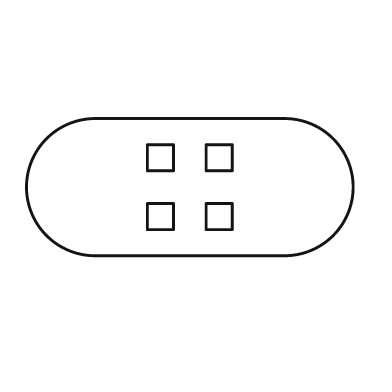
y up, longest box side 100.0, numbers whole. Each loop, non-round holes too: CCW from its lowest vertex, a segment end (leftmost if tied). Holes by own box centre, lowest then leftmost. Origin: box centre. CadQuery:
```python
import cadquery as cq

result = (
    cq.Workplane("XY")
    .moveTo(-29.0, -21.0)
    .lineTo(29.0, -21.0)
    .threePointArc((50.0, 0.0), (29.0, 21.0))
    .lineTo(-29.0, 21.0)
    .threePointArc((-50.0, 0.0), (-29.0, -21.0))
    .close()
    .moveTo(-13.0, -13.0)
    .lineTo(-5.0, -13.0)
    .lineTo(-5.0, -5.0)
    .lineTo(-13.0, -5.0)
    .close()
    .moveTo(5.0, -13.0)
    .lineTo(13.0, -13.0)
    .lineTo(13.0, -5.0)
    .lineTo(5.0, -5.0)
    .close()
    .moveTo(-13.0, 5.0)
    .lineTo(-5.0, 5.0)
    .lineTo(-5.0, 13.0)
    .lineTo(-13.0, 13.0)
    .close()
    .moveTo(5.0, 5.0)
    .lineTo(13.0, 5.0)
    .lineTo(13.0, 13.0)
    .lineTo(5.0, 13.0)
    .close()
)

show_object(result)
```